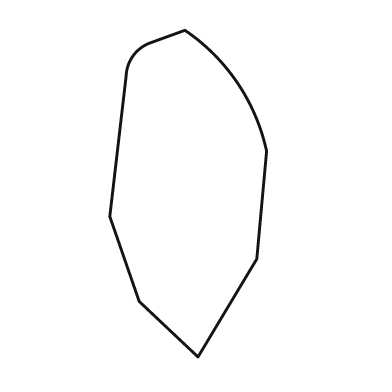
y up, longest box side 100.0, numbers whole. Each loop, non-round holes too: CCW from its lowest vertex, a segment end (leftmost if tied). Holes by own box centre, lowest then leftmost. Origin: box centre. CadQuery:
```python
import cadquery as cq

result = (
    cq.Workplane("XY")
    .moveTo(3.0, -50.0)
    .lineTo(21.0, -20.0)
    .lineTo(24.0, 13.0)
    .threePointArc((15.0, 34.0), (-1.0, 50.0))
    .lineTo(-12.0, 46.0)
    .threePointArc((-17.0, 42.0), (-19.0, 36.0))
    .lineTo(-24.0, -7.0)
    .lineTo(-15.0, -33.0)
    .close()
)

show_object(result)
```